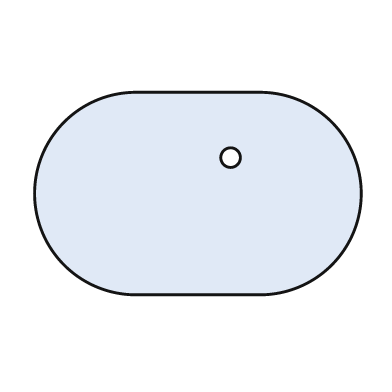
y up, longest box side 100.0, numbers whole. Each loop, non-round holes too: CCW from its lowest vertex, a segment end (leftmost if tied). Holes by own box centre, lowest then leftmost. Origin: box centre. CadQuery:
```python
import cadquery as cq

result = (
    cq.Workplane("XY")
    .moveTo(-19.0, -31.0)
    .lineTo(19.0, -31.0)
    .threePointArc((50.0, 0.0), (19.0, 31.0))
    .lineTo(-19.0, 31.0)
    .threePointArc((-50.0, 0.0), (-19.0, -31.0))
    .close()
    .moveTo(10.0, 11.0)
    .circle(3.0)
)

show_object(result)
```